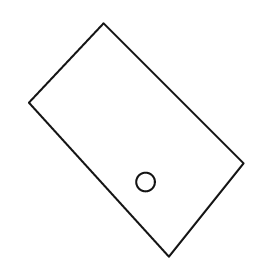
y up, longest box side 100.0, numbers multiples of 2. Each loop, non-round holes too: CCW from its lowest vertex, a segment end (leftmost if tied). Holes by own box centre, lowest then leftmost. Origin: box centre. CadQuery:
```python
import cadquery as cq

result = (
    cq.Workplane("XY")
    .moveTo(14.0, -50.0)
    .lineTo(46.0, -10.0)
    .lineTo(-14.0, 50.0)
    .lineTo(-46.0, 16.0)
    .close()
    .moveTo(4.0, -18.0)
    .circle(4.0)
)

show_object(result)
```